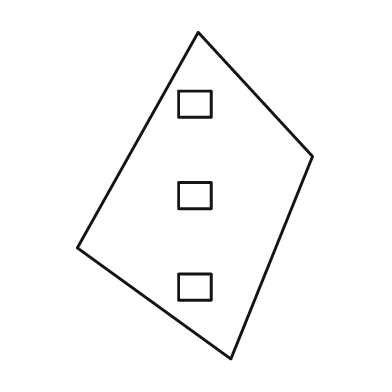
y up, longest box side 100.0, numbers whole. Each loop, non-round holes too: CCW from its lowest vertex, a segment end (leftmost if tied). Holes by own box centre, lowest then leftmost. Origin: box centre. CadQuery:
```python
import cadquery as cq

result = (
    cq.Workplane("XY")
    .moveTo(11.0, -50.0)
    .lineTo(36.0, 12.0)
    .lineTo(1.0, 50.0)
    .lineTo(-36.0, -16.0)
    .close()
    .moveTo(-5.0, -32.0)
    .lineTo(5.0, -32.0)
    .lineTo(5.0, -24.0)
    .lineTo(-5.0, -24.0)
    .close()
    .moveTo(-5.0, -4.0)
    .lineTo(5.0, -4.0)
    .lineTo(5.0, 4.0)
    .lineTo(-5.0, 4.0)
    .close()
    .moveTo(-5.0, 24.0)
    .lineTo(5.0, 24.0)
    .lineTo(5.0, 32.0)
    .lineTo(-5.0, 32.0)
    .close()
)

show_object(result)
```